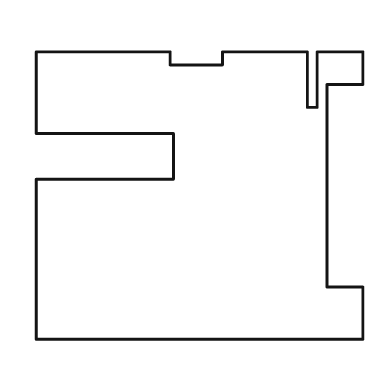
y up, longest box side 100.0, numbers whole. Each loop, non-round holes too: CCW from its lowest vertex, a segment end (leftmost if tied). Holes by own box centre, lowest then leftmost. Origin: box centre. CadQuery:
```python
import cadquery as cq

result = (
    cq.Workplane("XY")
    .moveTo(-50.0, -44.0)
    .lineTo(50.0, -44.0)
    .lineTo(50.0, -28.0)
    .lineTo(39.0, -28.0)
    .lineTo(39.0, 34.0)
    .lineTo(50.0, 34.0)
    .lineTo(50.0, 44.0)
    .lineTo(36.0, 44.0)
    .lineTo(36.0, 27.0)
    .lineTo(33.0, 27.0)
    .lineTo(33.0, 44.0)
    .lineTo(7.0, 44.0)
    .lineTo(7.0, 40.0)
    .lineTo(-9.0, 40.0)
    .lineTo(-9.0, 44.0)
    .lineTo(-50.0, 44.0)
    .lineTo(-50.0, 19.0)
    .lineTo(-8.0, 19.0)
    .lineTo(-8.0, 5.0)
    .lineTo(-50.0, 5.0)
    .close()
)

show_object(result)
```